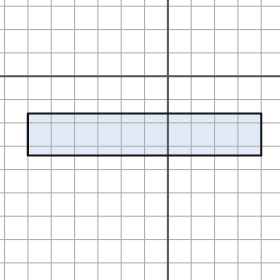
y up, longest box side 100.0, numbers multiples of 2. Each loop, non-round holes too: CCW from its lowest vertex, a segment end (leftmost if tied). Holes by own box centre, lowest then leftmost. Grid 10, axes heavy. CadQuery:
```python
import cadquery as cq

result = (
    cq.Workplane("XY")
    .moveTo(-60.0, -34.0)
    .lineTo(40.0, -34.0)
    .lineTo(40.0, -16.0)
    .lineTo(-60.0, -16.0)
    .close()
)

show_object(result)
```